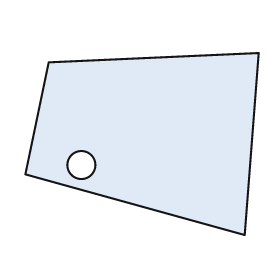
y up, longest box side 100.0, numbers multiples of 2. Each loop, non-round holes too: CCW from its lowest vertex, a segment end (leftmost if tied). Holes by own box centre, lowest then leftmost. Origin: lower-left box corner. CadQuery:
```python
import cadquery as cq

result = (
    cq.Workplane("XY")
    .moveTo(94.0, 0.0)
    .lineTo(100.0, 78.0)
    .lineTo(10.0, 74.0)
    .lineTo(0.0, 26.0)
    .close()
    .moveTo(24.0, 30.0)
    .circle(6.0)
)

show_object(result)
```